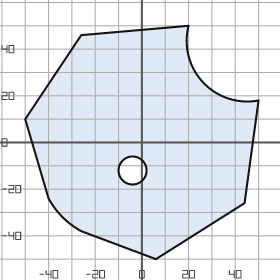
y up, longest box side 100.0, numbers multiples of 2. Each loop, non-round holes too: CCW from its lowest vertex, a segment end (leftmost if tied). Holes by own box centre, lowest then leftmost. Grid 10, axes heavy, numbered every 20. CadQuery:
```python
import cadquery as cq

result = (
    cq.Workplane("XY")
    .moveTo(6.0, -50.0)
    .lineTo(44.0, -26.0)
    .lineTo(50.0, 18.0)
    .threePointArc((26.0, 26.0), (20.0, 50.0))
    .lineTo(-26.0, 46.0)
    .lineTo(-50.0, 10.0)
    .lineTo(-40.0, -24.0)
    .threePointArc((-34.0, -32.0), (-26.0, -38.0))
    .close()
    .moveTo(-4.0, -12.0)
    .circle(6.0)
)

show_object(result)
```